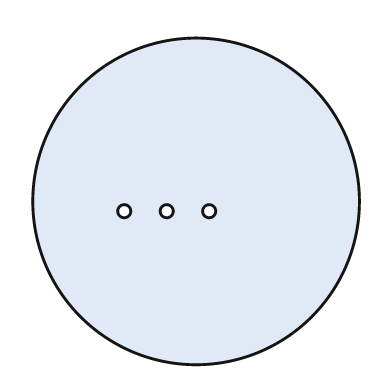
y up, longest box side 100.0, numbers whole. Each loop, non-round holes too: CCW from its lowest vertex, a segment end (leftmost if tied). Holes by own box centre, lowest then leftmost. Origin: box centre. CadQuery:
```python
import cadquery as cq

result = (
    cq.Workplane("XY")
    .moveTo(0.0, 0.0)
    .circle(50.0)
    .moveTo(-22.0, -3.0)
    .circle(2.0)
    .moveTo(-9.0, -3.0)
    .circle(2.0)
    .moveTo(4.0, -3.0)
    .circle(2.0)
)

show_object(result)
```